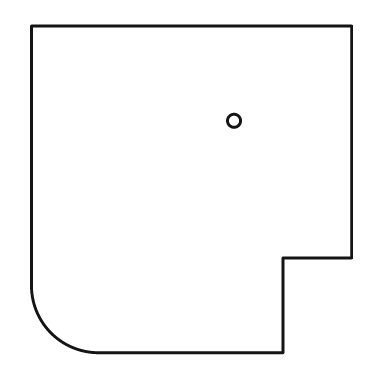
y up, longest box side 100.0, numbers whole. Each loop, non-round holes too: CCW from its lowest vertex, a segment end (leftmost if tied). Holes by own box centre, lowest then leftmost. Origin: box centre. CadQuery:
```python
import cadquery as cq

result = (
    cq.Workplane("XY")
    .moveTo(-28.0, -50.0)
    .lineTo(28.0, -50.0)
    .lineTo(28.0, -21.0)
    .lineTo(49.0, -21.0)
    .lineTo(49.0, 50.0)
    .lineTo(-49.0, 50.0)
    .lineTo(-49.0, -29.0)
    .threePointArc((-43.0, -44.0), (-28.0, -50.0))
    .close()
    .moveTo(13.0, 21.0)
    .circle(2.0)
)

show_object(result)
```